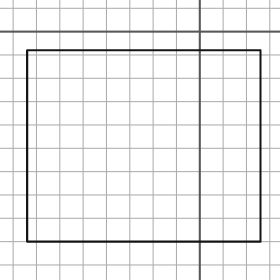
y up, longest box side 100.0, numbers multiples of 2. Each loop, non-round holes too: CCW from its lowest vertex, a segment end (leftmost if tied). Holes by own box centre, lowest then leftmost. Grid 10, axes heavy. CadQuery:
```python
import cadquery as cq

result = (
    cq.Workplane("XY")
    .moveTo(-74.0, -90.0)
    .lineTo(26.0, -90.0)
    .lineTo(26.0, -8.0)
    .lineTo(-74.0, -8.0)
    .close()
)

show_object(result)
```